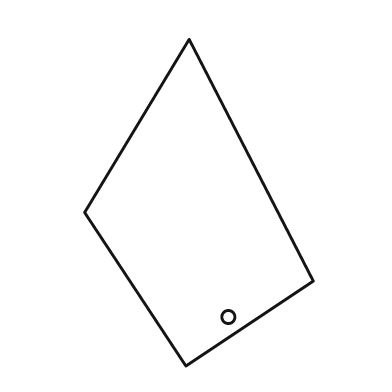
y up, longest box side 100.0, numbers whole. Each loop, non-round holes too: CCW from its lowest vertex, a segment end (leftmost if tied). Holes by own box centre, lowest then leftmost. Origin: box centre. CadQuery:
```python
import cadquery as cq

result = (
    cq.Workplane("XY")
    .moveTo(-4.0, -50.0)
    .lineTo(35.0, -24.0)
    .lineTo(-3.0, 50.0)
    .lineTo(-35.0, -3.0)
    .close()
    .moveTo(9.0, -35.0)
    .circle(2.0)
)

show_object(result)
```